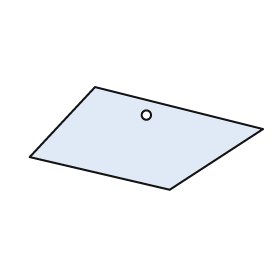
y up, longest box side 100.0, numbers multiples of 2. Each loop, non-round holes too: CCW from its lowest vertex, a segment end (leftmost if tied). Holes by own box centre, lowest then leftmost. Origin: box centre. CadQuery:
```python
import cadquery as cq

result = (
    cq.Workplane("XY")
    .moveTo(10.0, -22.0)
    .lineTo(50.0, 4.0)
    .lineTo(-22.0, 22.0)
    .lineTo(-50.0, -8.0)
    .close()
    .moveTo(0.0, 10.0)
    .circle(2.0)
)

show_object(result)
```